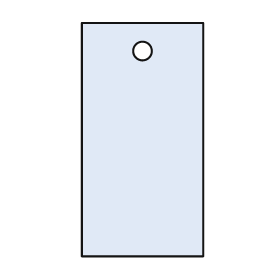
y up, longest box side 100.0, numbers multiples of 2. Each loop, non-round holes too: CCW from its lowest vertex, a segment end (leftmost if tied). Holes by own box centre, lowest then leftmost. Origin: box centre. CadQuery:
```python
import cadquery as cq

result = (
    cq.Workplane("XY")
    .moveTo(-26.0, -50.0)
    .lineTo(26.0, -50.0)
    .lineTo(26.0, 50.0)
    .lineTo(-26.0, 50.0)
    .close()
    .moveTo(0.0, 38.0)
    .circle(4.0)
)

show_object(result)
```